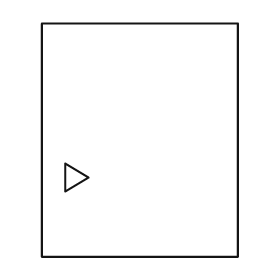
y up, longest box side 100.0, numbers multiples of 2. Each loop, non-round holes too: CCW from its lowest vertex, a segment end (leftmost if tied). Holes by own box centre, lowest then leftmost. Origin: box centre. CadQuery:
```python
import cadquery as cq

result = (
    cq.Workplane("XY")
    .moveTo(-42.0, -50.0)
    .lineTo(42.0, -50.0)
    .lineTo(42.0, 50.0)
    .lineTo(-42.0, 50.0)
    .close()
    .moveTo(-32.0, -22.0)
    .lineTo(-22.0, -16.0)
    .lineTo(-32.0, -10.0)
    .close()
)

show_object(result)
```